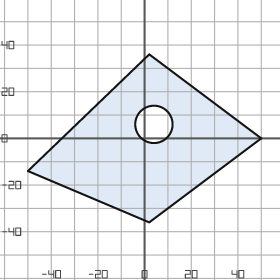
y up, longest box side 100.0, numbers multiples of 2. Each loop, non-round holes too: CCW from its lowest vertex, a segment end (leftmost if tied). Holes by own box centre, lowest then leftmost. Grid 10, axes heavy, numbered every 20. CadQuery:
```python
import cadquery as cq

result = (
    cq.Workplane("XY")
    .moveTo(2.0, -36.0)
    .lineTo(50.0, 0.0)
    .lineTo(2.0, 36.0)
    .lineTo(-50.0, -14.0)
    .close()
    .moveTo(4.0, 6.0)
    .circle(8.0)
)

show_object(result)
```